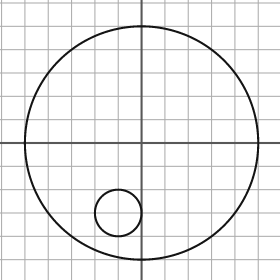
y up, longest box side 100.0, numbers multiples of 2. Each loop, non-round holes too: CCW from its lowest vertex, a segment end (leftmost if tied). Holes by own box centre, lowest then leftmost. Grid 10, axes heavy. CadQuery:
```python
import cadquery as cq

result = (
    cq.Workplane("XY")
    .moveTo(0.0, 0.0)
    .circle(50.0)
    .moveTo(-10.0, -30.0)
    .circle(10.0)
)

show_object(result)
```